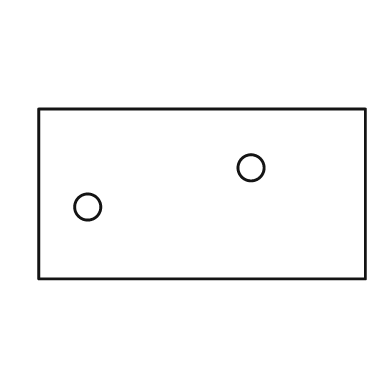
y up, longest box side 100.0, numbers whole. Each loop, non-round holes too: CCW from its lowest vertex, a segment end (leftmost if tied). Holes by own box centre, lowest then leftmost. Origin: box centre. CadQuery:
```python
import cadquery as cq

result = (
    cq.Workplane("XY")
    .moveTo(-50.0, -26.0)
    .lineTo(50.0, -26.0)
    .lineTo(50.0, 26.0)
    .lineTo(-50.0, 26.0)
    .close()
    .moveTo(-35.0, -4.0)
    .circle(4.0)
    .moveTo(15.0, 8.0)
    .circle(4.0)
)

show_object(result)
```